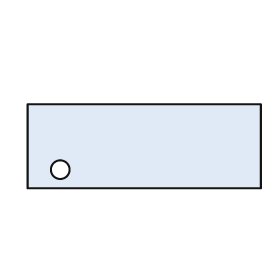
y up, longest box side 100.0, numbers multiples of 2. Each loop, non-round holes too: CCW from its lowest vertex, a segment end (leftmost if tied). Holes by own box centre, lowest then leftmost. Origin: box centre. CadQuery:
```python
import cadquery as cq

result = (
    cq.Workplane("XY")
    .moveTo(-50.0, -18.0)
    .lineTo(50.0, -18.0)
    .lineTo(50.0, 18.0)
    .lineTo(-50.0, 18.0)
    .close()
    .moveTo(-36.0, -10.0)
    .circle(4.0)
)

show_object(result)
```